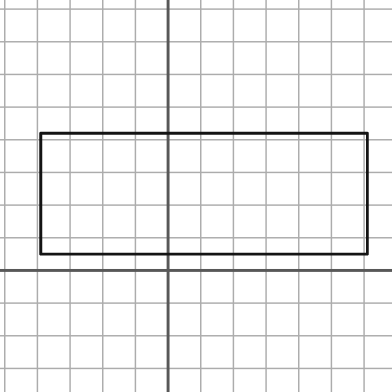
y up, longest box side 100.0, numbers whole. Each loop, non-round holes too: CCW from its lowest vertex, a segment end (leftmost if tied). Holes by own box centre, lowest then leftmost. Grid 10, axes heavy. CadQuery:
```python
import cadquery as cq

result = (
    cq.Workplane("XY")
    .moveTo(-39.0, 5.0)
    .lineTo(61.0, 5.0)
    .lineTo(61.0, 42.0)
    .lineTo(-39.0, 42.0)
    .close()
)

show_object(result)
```